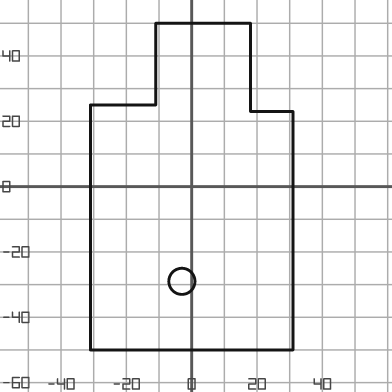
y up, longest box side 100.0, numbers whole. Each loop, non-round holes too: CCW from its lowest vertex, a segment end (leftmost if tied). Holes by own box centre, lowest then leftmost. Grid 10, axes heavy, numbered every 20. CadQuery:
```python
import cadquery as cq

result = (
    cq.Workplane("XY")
    .moveTo(-31.0, -50.0)
    .lineTo(31.0, -50.0)
    .lineTo(31.0, 23.0)
    .lineTo(18.0, 23.0)
    .lineTo(18.0, 50.0)
    .lineTo(-11.0, 50.0)
    .lineTo(-11.0, 25.0)
    .lineTo(-31.0, 25.0)
    .close()
    .moveTo(-3.0, -29.0)
    .circle(4.0)
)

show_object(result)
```